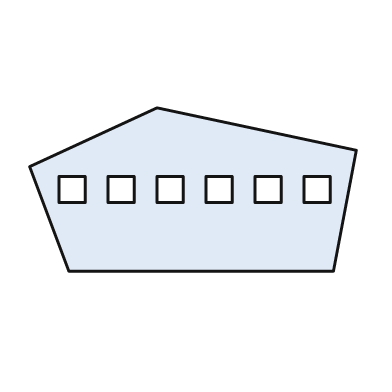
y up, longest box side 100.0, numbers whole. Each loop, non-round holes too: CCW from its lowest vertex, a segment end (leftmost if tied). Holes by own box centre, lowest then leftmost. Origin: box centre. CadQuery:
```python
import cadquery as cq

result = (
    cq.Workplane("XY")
    .moveTo(-38.0, -25.0)
    .lineTo(43.0, -25.0)
    .lineTo(50.0, 12.0)
    .lineTo(-11.0, 25.0)
    .lineTo(-50.0, 7.0)
    .close()
    .moveTo(-41.0, -4.0)
    .lineTo(-33.0, -4.0)
    .lineTo(-33.0, 4.0)
    .lineTo(-41.0, 4.0)
    .close()
    .moveTo(-26.0, -4.0)
    .lineTo(-18.0, -4.0)
    .lineTo(-18.0, 4.0)
    .lineTo(-26.0, 4.0)
    .close()
    .moveTo(-11.0, -4.0)
    .lineTo(-3.0, -4.0)
    .lineTo(-3.0, 4.0)
    .lineTo(-11.0, 4.0)
    .close()
    .moveTo(4.0, -4.0)
    .lineTo(12.0, -4.0)
    .lineTo(12.0, 4.0)
    .lineTo(4.0, 4.0)
    .close()
    .moveTo(19.0, -4.0)
    .lineTo(27.0, -4.0)
    .lineTo(27.0, 4.0)
    .lineTo(19.0, 4.0)
    .close()
    .moveTo(34.0, -4.0)
    .lineTo(42.0, -4.0)
    .lineTo(42.0, 4.0)
    .lineTo(34.0, 4.0)
    .close()
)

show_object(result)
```